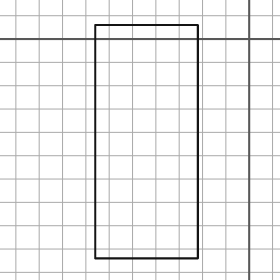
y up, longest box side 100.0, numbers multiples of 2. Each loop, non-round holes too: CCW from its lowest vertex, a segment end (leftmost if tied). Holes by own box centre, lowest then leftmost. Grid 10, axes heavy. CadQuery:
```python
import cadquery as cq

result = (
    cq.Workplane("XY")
    .moveTo(-66.0, -94.0)
    .lineTo(-22.0, -94.0)
    .lineTo(-22.0, 6.0)
    .lineTo(-66.0, 6.0)
    .close()
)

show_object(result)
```